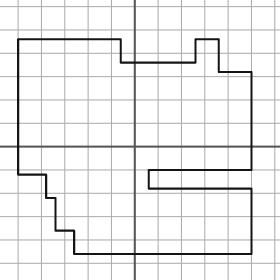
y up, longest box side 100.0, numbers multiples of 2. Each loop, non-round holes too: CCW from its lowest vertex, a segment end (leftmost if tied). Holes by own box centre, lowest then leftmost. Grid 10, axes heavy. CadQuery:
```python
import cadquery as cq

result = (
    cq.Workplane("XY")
    .moveTo(-26.0, -46.0)
    .lineTo(50.0, -46.0)
    .lineTo(50.0, -18.0)
    .lineTo(6.0, -18.0)
    .lineTo(6.0, -10.0)
    .lineTo(50.0, -10.0)
    .lineTo(50.0, 32.0)
    .lineTo(36.0, 32.0)
    .lineTo(36.0, 46.0)
    .lineTo(26.0, 46.0)
    .lineTo(26.0, 36.0)
    .lineTo(-6.0, 36.0)
    .lineTo(-6.0, 46.0)
    .lineTo(-50.0, 46.0)
    .lineTo(-50.0, -12.0)
    .lineTo(-38.0, -12.0)
    .lineTo(-38.0, -22.0)
    .lineTo(-34.0, -22.0)
    .lineTo(-34.0, -36.0)
    .lineTo(-26.0, -36.0)
    .close()
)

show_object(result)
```